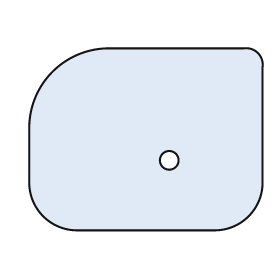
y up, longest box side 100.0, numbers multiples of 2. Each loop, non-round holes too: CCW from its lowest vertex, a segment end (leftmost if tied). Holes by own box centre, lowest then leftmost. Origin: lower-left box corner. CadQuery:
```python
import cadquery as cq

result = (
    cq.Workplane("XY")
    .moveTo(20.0, 0.0)
    .lineTo(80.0, 0.0)
    .threePointArc((94.0, 6.0), (100.0, 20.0))
    .lineTo(100.0, 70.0)
    .threePointArc((98.0, 76.0), (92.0, 78.0))
    .lineTo(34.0, 78.0)
    .threePointArc((10.0, 68.0), (0.0, 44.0))
    .lineTo(0.0, 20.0)
    .threePointArc((6.0, 6.0), (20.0, 0.0))
    .close()
    .moveTo(60.0, 30.0)
    .circle(4.0)
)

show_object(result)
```